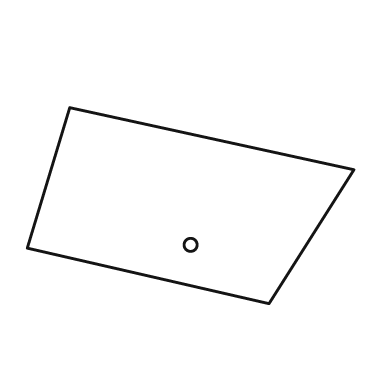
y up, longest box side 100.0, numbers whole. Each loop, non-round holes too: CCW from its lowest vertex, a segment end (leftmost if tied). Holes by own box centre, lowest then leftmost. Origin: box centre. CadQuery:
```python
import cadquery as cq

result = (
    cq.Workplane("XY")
    .moveTo(24.0, -30.0)
    .lineTo(50.0, 11.0)
    .lineTo(-37.0, 30.0)
    .lineTo(-50.0, -13.0)
    .close()
    .moveTo(0.0, -12.0)
    .circle(2.0)
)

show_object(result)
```